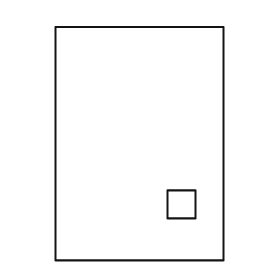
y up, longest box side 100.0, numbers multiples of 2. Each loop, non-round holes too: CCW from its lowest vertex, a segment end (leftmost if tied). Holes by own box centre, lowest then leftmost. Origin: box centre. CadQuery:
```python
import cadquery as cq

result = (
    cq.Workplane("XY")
    .moveTo(-36.0, -50.0)
    .lineTo(36.0, -50.0)
    .lineTo(36.0, 50.0)
    .lineTo(-36.0, 50.0)
    .close()
    .moveTo(12.0, -32.0)
    .lineTo(24.0, -32.0)
    .lineTo(24.0, -20.0)
    .lineTo(12.0, -20.0)
    .close()
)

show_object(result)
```